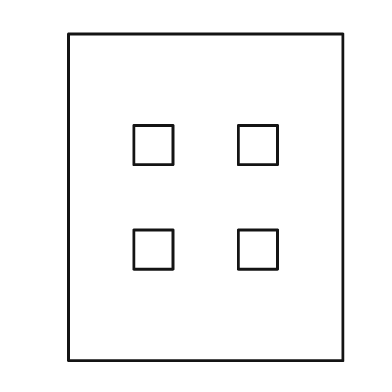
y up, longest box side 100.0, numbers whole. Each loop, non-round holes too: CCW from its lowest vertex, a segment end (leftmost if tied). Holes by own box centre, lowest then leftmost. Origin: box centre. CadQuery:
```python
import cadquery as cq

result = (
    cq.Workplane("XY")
    .moveTo(-42.0, -50.0)
    .lineTo(42.0, -50.0)
    .lineTo(42.0, 50.0)
    .lineTo(-42.0, 50.0)
    .close()
    .moveTo(-22.0, -22.0)
    .lineTo(-10.0, -22.0)
    .lineTo(-10.0, -10.0)
    .lineTo(-22.0, -10.0)
    .close()
    .moveTo(10.0, -22.0)
    .lineTo(22.0, -22.0)
    .lineTo(22.0, -10.0)
    .lineTo(10.0, -10.0)
    .close()
    .moveTo(-22.0, 10.0)
    .lineTo(-10.0, 10.0)
    .lineTo(-10.0, 22.0)
    .lineTo(-22.0, 22.0)
    .close()
    .moveTo(10.0, 10.0)
    .lineTo(22.0, 10.0)
    .lineTo(22.0, 22.0)
    .lineTo(10.0, 22.0)
    .close()
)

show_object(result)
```